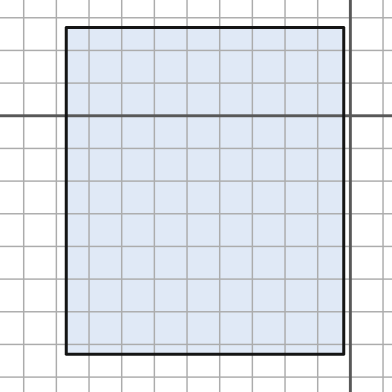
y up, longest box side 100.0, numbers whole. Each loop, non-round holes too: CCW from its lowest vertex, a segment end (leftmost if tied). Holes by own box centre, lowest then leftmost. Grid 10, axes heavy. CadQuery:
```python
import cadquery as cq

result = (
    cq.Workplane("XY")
    .moveTo(-87.0, -73.0)
    .lineTo(-2.0, -73.0)
    .lineTo(-2.0, 27.0)
    .lineTo(-87.0, 27.0)
    .close()
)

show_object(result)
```